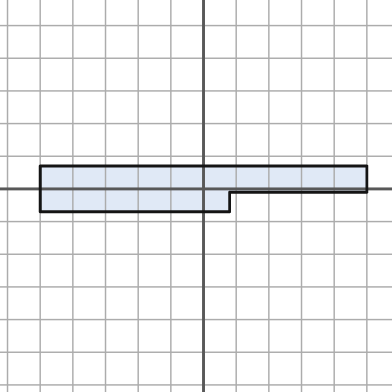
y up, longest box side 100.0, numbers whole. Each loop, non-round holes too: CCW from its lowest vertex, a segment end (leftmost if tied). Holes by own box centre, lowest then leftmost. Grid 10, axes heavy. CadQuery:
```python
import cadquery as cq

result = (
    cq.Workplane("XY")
    .moveTo(-50.0, -7.0)
    .lineTo(8.0, -7.0)
    .lineTo(8.0, -1.0)
    .lineTo(50.0, -1.0)
    .lineTo(50.0, 7.0)
    .lineTo(-50.0, 7.0)
    .close()
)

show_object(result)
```